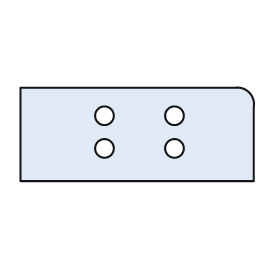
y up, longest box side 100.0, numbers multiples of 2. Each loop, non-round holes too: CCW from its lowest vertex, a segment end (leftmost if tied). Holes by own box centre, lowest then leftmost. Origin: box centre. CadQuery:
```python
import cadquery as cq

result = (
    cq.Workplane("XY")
    .moveTo(-50.0, -20.0)
    .lineTo(50.0, -20.0)
    .lineTo(50.0, 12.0)
    .threePointArc((48.0, 18.0), (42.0, 20.0))
    .lineTo(-50.0, 20.0)
    .close()
    .moveTo(-14.0, -6.0)
    .circle(4.0)
    .moveTo(16.0, -6.0)
    .circle(4.0)
    .moveTo(-14.0, 8.0)
    .circle(4.0)
    .moveTo(16.0, 8.0)
    .circle(4.0)
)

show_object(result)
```